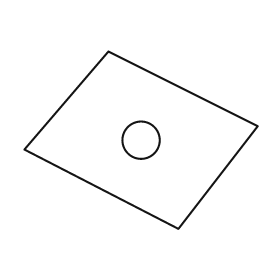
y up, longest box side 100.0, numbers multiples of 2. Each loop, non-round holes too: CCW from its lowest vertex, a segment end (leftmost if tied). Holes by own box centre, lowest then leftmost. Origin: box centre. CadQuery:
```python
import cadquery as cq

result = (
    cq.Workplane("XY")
    .moveTo(16.0, -38.0)
    .lineTo(50.0, 6.0)
    .lineTo(-14.0, 38.0)
    .lineTo(-50.0, -4.0)
    .close()
    .moveTo(0.0, 0.0)
    .circle(8.0)
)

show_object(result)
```